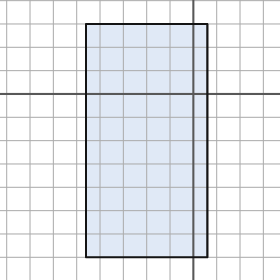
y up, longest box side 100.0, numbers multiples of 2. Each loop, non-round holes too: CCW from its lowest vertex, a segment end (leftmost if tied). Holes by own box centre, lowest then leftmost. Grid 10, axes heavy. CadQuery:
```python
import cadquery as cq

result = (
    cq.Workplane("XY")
    .moveTo(-46.0, -70.0)
    .lineTo(6.0, -70.0)
    .lineTo(6.0, 30.0)
    .lineTo(-46.0, 30.0)
    .close()
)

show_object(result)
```